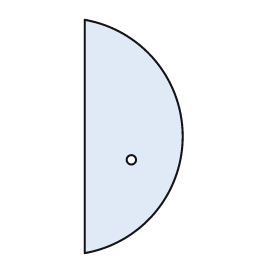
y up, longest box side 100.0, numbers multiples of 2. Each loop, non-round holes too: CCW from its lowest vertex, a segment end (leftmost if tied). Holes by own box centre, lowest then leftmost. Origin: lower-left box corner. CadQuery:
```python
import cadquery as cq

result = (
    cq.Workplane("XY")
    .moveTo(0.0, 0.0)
    .threePointArc((42.0, 50.0), (0.0, 100.0))
    .close()
    .moveTo(20.0, 40.0)
    .circle(2.0)
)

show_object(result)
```